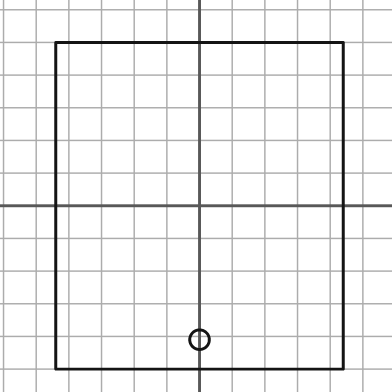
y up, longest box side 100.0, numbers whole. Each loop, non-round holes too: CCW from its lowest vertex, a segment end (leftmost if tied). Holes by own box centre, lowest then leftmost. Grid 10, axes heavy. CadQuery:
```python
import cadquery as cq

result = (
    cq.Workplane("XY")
    .moveTo(-44.0, -50.0)
    .lineTo(44.0, -50.0)
    .lineTo(44.0, 50.0)
    .lineTo(-44.0, 50.0)
    .close()
    .moveTo(0.0, -41.0)
    .circle(3.0)
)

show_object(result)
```